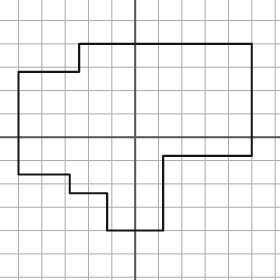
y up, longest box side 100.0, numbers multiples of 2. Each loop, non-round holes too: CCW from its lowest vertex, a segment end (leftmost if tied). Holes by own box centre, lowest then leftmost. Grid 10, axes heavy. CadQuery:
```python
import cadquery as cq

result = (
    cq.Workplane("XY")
    .moveTo(-12.0, -40.0)
    .lineTo(12.0, -40.0)
    .lineTo(12.0, -8.0)
    .lineTo(50.0, -8.0)
    .lineTo(50.0, 40.0)
    .lineTo(-24.0, 40.0)
    .lineTo(-24.0, 28.0)
    .lineTo(-50.0, 28.0)
    .lineTo(-50.0, -16.0)
    .lineTo(-28.0, -16.0)
    .lineTo(-28.0, -24.0)
    .lineTo(-12.0, -24.0)
    .close()
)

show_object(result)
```